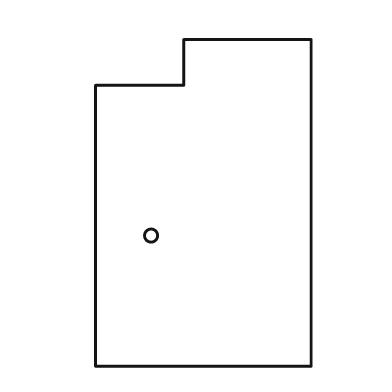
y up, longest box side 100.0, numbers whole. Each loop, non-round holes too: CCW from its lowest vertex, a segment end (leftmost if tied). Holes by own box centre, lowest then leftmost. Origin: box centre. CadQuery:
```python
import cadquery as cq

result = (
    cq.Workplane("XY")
    .moveTo(-33.0, -50.0)
    .lineTo(33.0, -50.0)
    .lineTo(33.0, 50.0)
    .lineTo(-6.0, 50.0)
    .lineTo(-6.0, 36.0)
    .lineTo(-33.0, 36.0)
    .close()
    .moveTo(-16.0, -10.0)
    .circle(2.0)
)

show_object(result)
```